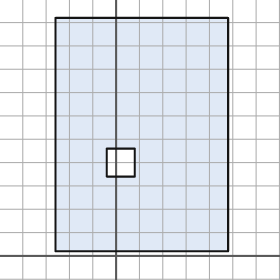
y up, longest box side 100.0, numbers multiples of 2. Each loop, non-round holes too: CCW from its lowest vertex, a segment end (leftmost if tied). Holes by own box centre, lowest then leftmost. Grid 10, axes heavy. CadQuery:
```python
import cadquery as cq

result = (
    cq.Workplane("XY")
    .moveTo(-26.0, 2.0)
    .lineTo(48.0, 2.0)
    .lineTo(48.0, 102.0)
    .lineTo(-26.0, 102.0)
    .close()
    .moveTo(-4.0, 34.0)
    .lineTo(8.0, 34.0)
    .lineTo(8.0, 46.0)
    .lineTo(-4.0, 46.0)
    .close()
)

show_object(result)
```